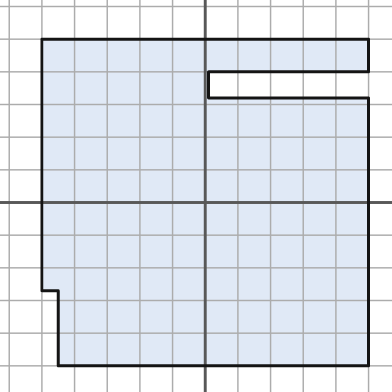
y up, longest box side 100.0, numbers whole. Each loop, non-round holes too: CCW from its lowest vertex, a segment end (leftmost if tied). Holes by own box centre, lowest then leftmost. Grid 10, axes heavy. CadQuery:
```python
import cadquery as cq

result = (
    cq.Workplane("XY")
    .moveTo(-45.0, -50.0)
    .lineTo(50.0, -50.0)
    .lineTo(50.0, 32.0)
    .lineTo(1.0, 32.0)
    .lineTo(1.0, 40.0)
    .lineTo(50.0, 40.0)
    .lineTo(50.0, 50.0)
    .lineTo(-50.0, 50.0)
    .lineTo(-50.0, -27.0)
    .lineTo(-45.0, -27.0)
    .close()
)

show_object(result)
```